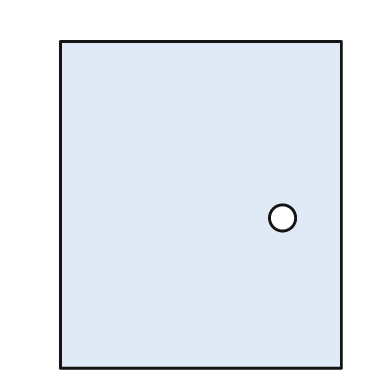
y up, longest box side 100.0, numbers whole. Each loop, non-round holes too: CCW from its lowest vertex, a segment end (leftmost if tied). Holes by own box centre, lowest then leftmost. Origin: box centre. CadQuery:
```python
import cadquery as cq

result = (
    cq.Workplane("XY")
    .moveTo(-43.0, -50.0)
    .lineTo(43.0, -50.0)
    .lineTo(43.0, 50.0)
    .lineTo(-43.0, 50.0)
    .close()
    .moveTo(25.0, -4.0)
    .circle(4.0)
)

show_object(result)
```